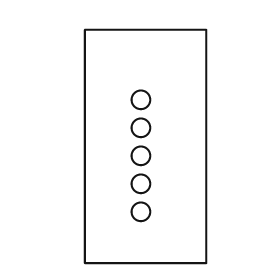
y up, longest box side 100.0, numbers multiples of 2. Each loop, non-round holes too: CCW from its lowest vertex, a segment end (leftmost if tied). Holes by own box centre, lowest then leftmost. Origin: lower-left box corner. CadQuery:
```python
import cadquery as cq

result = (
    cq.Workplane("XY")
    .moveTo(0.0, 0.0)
    .lineTo(52.0, 0.0)
    .lineTo(52.0, 100.0)
    .lineTo(0.0, 100.0)
    .close()
    .moveTo(24.0, 22.0)
    .circle(4.0)
    .moveTo(24.0, 34.0)
    .circle(4.0)
    .moveTo(24.0, 46.0)
    .circle(4.0)
    .moveTo(24.0, 58.0)
    .circle(4.0)
    .moveTo(24.0, 70.0)
    .circle(4.0)
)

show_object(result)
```